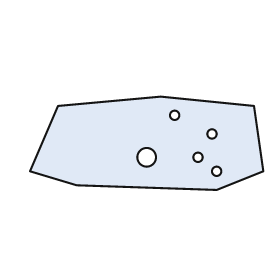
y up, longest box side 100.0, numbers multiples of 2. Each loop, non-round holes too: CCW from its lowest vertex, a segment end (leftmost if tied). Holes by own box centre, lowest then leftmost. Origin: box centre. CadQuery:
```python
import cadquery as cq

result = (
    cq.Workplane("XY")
    .moveTo(30.0, -20.0)
    .lineTo(50.0, -12.0)
    .lineTo(46.0, 16.0)
    .lineTo(6.0, 20.0)
    .lineTo(-38.0, 16.0)
    .lineTo(-50.0, -12.0)
    .lineTo(-30.0, -18.0)
    .close()
    .moveTo(30.0, -12.0)
    .circle(2.0)
    .moveTo(0.0, -6.0)
    .circle(4.0)
    .moveTo(22.0, -6.0)
    .circle(2.0)
    .moveTo(28.0, 4.0)
    .circle(2.0)
    .moveTo(12.0, 12.0)
    .circle(2.0)
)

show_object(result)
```